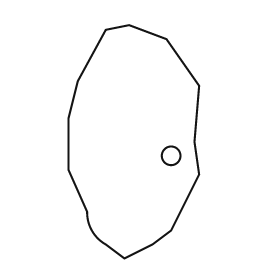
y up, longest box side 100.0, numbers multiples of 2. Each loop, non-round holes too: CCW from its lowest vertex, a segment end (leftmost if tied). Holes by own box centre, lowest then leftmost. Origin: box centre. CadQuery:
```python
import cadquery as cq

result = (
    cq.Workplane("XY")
    .moveTo(-4.0, -50.0)
    .lineTo(8.0, -44.0)
    .lineTo(16.0, -38.0)
    .lineTo(28.0, -14.0)
    .lineTo(26.0, 0.0)
    .lineTo(28.0, 24.0)
    .lineTo(14.0, 44.0)
    .lineTo(-2.0, 50.0)
    .lineTo(-12.0, 48.0)
    .lineTo(-24.0, 26.0)
    .lineTo(-28.0, 10.0)
    .lineTo(-28.0, -12.0)
    .lineTo(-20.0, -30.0)
    .threePointArc((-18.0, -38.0), (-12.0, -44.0))
    .close()
    .moveTo(16.0, -6.0)
    .circle(4.0)
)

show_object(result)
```